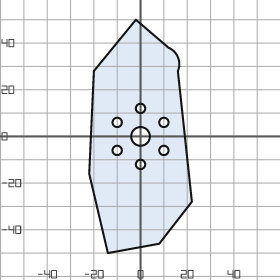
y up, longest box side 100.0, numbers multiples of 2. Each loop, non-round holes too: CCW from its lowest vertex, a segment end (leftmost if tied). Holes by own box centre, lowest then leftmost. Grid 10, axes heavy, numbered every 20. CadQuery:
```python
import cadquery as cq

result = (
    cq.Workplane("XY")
    .moveTo(-14.0, -50.0)
    .lineTo(8.0, -46.0)
    .lineTo(22.0, -28.0)
    .lineTo(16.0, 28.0)
    .threePointArc((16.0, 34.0), (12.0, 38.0))
    .lineTo(-2.0, 50.0)
    .lineTo(-20.0, 28.0)
    .lineTo(-22.0, -16.0)
    .close()
    .moveTo(0.0, -12.0)
    .circle(2.0)
    .moveTo(-10.0, -6.0)
    .circle(2.0)
    .moveTo(10.0, -6.0)
    .circle(2.0)
    .moveTo(0.0, 0.0)
    .circle(4.0)
    .moveTo(-10.0, 6.0)
    .circle(2.0)
    .moveTo(10.0, 6.0)
    .circle(2.0)
    .moveTo(0.0, 12.0)
    .circle(2.0)
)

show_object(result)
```